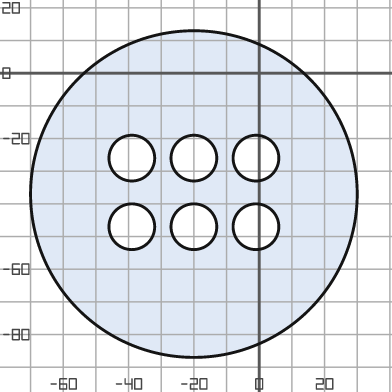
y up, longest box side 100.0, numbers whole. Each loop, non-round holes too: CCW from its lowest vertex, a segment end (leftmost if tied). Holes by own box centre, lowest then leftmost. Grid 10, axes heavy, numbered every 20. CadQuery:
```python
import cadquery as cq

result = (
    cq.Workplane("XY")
    .moveTo(-20.0, -37.0)
    .circle(50.0)
    .moveTo(-39.0, -47.0)
    .circle(7.0)
    .moveTo(-20.0, -47.0)
    .circle(7.0)
    .moveTo(-1.0, -47.0)
    .circle(7.0)
    .moveTo(-39.0, -26.0)
    .circle(7.0)
    .moveTo(-20.0, -26.0)
    .circle(7.0)
    .moveTo(-1.0, -26.0)
    .circle(7.0)
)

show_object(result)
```